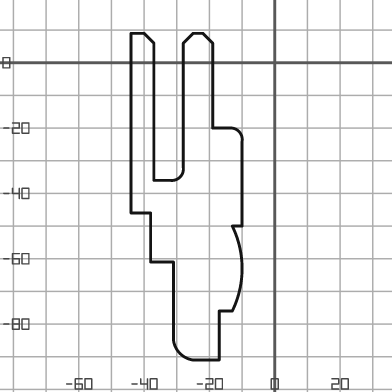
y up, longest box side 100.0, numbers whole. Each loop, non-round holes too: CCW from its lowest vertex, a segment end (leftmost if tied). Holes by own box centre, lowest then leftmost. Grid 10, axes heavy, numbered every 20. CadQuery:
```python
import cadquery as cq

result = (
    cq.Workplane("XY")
    .moveTo(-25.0, -91.0)
    .lineTo(-17.0, -91.0)
    .lineTo(-17.0, -76.0)
    .lineTo(-13.0, -76.0)
    .threePointArc((-10.0, -63.0), (-13.0, -50.0))
    .lineTo(-10.0, -50.0)
    .lineTo(-10.0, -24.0)
    .threePointArc((-11.0, -21.0), (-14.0, -20.0))
    .lineTo(-19.0, -20.0)
    .lineTo(-19.0, 6.0)
    .lineTo(-22.0, 9.0)
    .lineTo(-25.0, 9.0)
    .lineTo(-28.0, 6.0)
    .lineTo(-28.0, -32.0)
    .threePointArc((-29.0, -35.0), (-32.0, -36.0))
    .lineTo(-37.0, -36.0)
    .lineTo(-37.0, 6.0)
    .lineTo(-40.0, 9.0)
    .lineTo(-44.0, 9.0)
    .lineTo(-44.0, -46.0)
    .lineTo(-38.0, -46.0)
    .lineTo(-38.0, -61.0)
    .lineTo(-31.0, -61.0)
    .lineTo(-31.0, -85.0)
    .threePointArc((-29.0, -89.0), (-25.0, -91.0))
    .close()
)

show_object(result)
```